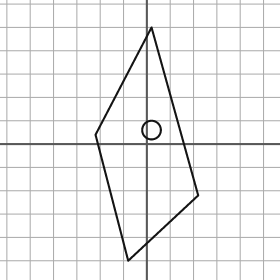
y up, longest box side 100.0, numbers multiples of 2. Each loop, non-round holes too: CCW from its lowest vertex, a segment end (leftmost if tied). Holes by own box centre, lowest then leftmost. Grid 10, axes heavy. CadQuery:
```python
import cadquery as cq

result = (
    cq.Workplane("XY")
    .moveTo(-8.0, -50.0)
    .lineTo(22.0, -22.0)
    .lineTo(2.0, 50.0)
    .lineTo(-22.0, 4.0)
    .close()
    .moveTo(2.0, 6.0)
    .circle(4.0)
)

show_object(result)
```